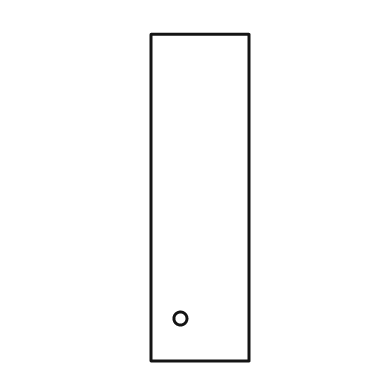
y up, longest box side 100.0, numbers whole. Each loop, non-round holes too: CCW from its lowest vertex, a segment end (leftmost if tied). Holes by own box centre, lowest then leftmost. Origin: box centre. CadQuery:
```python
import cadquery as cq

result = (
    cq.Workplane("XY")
    .moveTo(-15.0, -50.0)
    .lineTo(15.0, -50.0)
    .lineTo(15.0, 50.0)
    .lineTo(-15.0, 50.0)
    .close()
    .moveTo(-6.0, -37.0)
    .circle(2.0)
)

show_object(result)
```